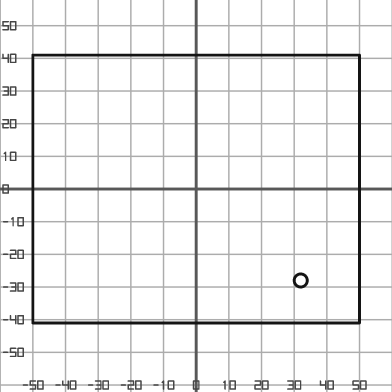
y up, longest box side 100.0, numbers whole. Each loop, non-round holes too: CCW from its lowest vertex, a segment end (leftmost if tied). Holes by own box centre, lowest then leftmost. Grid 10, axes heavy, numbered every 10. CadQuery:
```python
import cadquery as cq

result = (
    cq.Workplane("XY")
    .moveTo(-50.0, -41.0)
    .lineTo(50.0, -41.0)
    .lineTo(50.0, 41.0)
    .lineTo(-50.0, 41.0)
    .close()
    .moveTo(32.0, -28.0)
    .circle(2.0)
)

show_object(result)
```